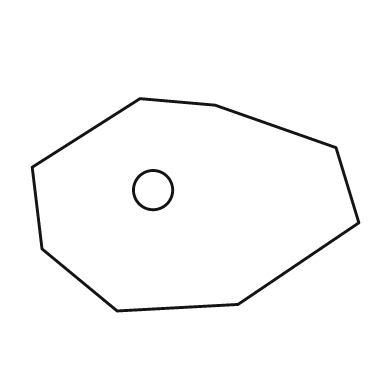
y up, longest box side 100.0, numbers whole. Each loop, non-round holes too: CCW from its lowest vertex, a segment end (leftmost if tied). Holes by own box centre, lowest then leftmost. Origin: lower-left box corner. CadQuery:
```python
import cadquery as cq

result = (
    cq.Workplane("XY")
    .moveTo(26.0, 0.0)
    .lineTo(63.0, 2.0)
    .lineTo(100.0, 27.0)
    .lineTo(93.0, 50.0)
    .lineTo(56.0, 63.0)
    .lineTo(33.0, 65.0)
    .lineTo(0.0, 44.0)
    .lineTo(3.0, 19.0)
    .close()
    .moveTo(37.0, 37.0)
    .circle(6.0)
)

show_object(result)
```